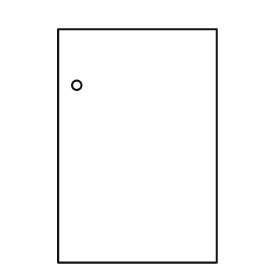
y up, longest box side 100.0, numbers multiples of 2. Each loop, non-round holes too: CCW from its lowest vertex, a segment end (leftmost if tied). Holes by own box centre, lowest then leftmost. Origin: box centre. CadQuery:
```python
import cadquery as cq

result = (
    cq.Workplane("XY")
    .moveTo(-34.0, -50.0)
    .lineTo(34.0, -50.0)
    .lineTo(34.0, 50.0)
    .lineTo(-34.0, 50.0)
    .close()
    .moveTo(-26.0, 26.0)
    .circle(2.0)
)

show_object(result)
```